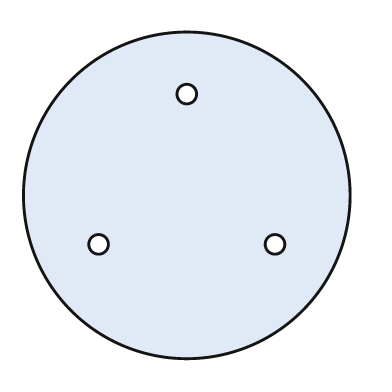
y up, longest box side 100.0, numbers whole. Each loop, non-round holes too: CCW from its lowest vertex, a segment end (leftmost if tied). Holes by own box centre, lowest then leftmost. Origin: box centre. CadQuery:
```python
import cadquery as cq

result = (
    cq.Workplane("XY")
    .moveTo(0.0, 0.0)
    .circle(50.0)
    .moveTo(-27.0, -15.0)
    .circle(3.0)
    .moveTo(27.0, -15.0)
    .circle(3.0)
    .moveTo(0.0, 31.0)
    .circle(3.0)
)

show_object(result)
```